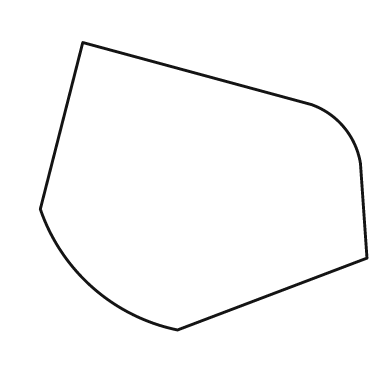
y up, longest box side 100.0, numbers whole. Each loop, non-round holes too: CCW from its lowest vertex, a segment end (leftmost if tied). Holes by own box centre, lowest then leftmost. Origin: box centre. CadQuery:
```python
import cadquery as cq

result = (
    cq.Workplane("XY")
    .moveTo(-8.0, -44.0)
    .lineTo(50.0, -22.0)
    .lineTo(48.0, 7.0)
    .threePointArc((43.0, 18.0), (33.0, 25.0))
    .lineTo(-37.0, 44.0)
    .lineTo(-50.0, -7.0)
    .threePointArc((-34.0, -31.0), (-8.0, -44.0))
    .close()
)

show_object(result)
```